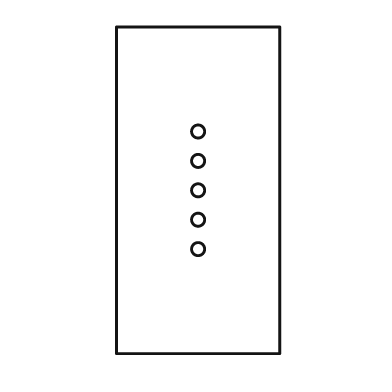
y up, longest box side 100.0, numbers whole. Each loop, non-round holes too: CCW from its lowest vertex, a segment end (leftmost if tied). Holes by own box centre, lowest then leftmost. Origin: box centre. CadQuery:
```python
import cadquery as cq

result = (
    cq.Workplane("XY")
    .moveTo(-25.0, -50.0)
    .lineTo(25.0, -50.0)
    .lineTo(25.0, 50.0)
    .lineTo(-25.0, 50.0)
    .close()
    .moveTo(0.0, -18.0)
    .circle(2.0)
    .moveTo(0.0, -9.0)
    .circle(2.0)
    .moveTo(0.0, 0.0)
    .circle(2.0)
    .moveTo(0.0, 9.0)
    .circle(2.0)
    .moveTo(0.0, 18.0)
    .circle(2.0)
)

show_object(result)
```